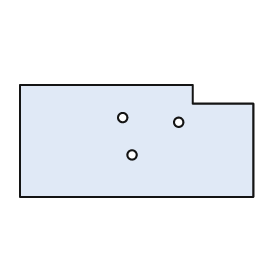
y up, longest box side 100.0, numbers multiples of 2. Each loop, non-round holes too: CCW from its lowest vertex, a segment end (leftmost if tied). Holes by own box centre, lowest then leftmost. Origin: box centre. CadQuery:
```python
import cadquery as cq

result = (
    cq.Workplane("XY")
    .moveTo(-50.0, -24.0)
    .lineTo(50.0, -24.0)
    .lineTo(50.0, 16.0)
    .lineTo(24.0, 16.0)
    .lineTo(24.0, 24.0)
    .lineTo(-50.0, 24.0)
    .close()
    .moveTo(-2.0, -6.0)
    .circle(2.0)
    .moveTo(18.0, 8.0)
    .circle(2.0)
    .moveTo(-6.0, 10.0)
    .circle(2.0)
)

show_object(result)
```